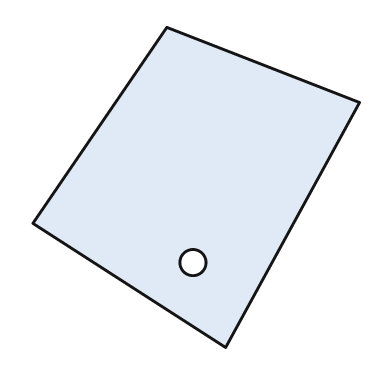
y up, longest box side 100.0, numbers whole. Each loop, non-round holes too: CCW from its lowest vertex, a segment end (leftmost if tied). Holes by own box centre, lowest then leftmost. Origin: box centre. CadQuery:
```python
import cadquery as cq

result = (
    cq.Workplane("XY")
    .moveTo(9.0, -49.0)
    .lineTo(50.0, 26.0)
    .lineTo(-9.0, 49.0)
    .lineTo(-50.0, -11.0)
    .close()
    .moveTo(-1.0, -23.0)
    .circle(4.0)
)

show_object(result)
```